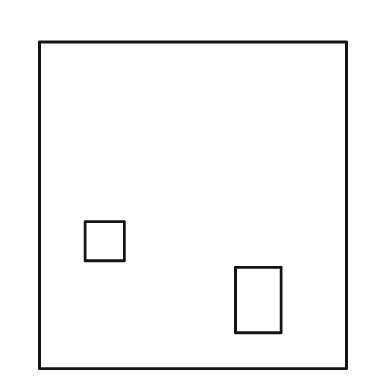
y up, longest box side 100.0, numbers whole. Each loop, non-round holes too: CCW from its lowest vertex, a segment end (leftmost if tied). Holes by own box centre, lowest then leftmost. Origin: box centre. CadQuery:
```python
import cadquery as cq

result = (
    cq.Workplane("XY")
    .moveTo(-47.0, -50.0)
    .lineTo(47.0, -50.0)
    .lineTo(47.0, 50.0)
    .lineTo(-47.0, 50.0)
    .close()
    .moveTo(13.0, -39.0)
    .lineTo(27.0, -39.0)
    .lineTo(27.0, -19.0)
    .lineTo(13.0, -19.0)
    .close()
    .moveTo(-33.0, -17.0)
    .lineTo(-21.0, -17.0)
    .lineTo(-21.0, -5.0)
    .lineTo(-33.0, -5.0)
    .close()
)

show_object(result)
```